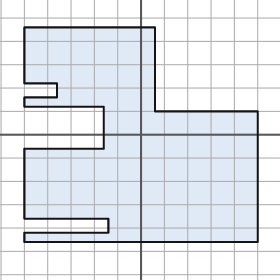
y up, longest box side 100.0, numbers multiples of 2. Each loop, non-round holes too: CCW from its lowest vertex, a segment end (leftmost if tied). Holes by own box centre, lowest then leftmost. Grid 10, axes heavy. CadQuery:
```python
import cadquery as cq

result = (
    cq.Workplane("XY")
    .moveTo(-50.0, -46.0)
    .lineTo(50.0, -46.0)
    .lineTo(50.0, 10.0)
    .lineTo(6.0, 10.0)
    .lineTo(6.0, 46.0)
    .lineTo(-50.0, 46.0)
    .lineTo(-50.0, 22.0)
    .lineTo(-36.0, 22.0)
    .lineTo(-36.0, 16.0)
    .lineTo(-50.0, 16.0)
    .lineTo(-50.0, 12.0)
    .lineTo(-16.0, 12.0)
    .lineTo(-16.0, -6.0)
    .lineTo(-50.0, -6.0)
    .lineTo(-50.0, -36.0)
    .lineTo(-14.0, -36.0)
    .lineTo(-14.0, -42.0)
    .lineTo(-50.0, -42.0)
    .close()
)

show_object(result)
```